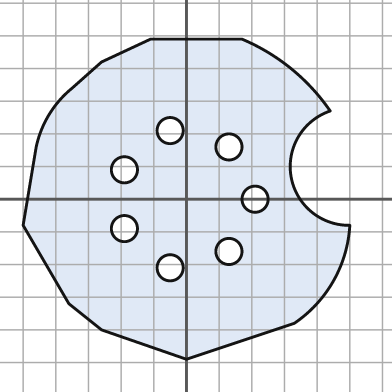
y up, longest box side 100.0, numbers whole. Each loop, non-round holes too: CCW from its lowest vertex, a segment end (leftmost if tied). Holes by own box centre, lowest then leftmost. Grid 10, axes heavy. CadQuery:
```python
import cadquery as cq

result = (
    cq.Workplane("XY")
    .moveTo(0.0, -49.0)
    .lineTo(33.0, -38.0)
    .threePointArc((45.0, -25.0), (50.0, -8.0))
    .threePointArc((32.0, 7.0), (44.0, 27.0))
    .threePointArc((32.0, 40.0), (17.0, 49.0))
    .lineTo(-11.0, 49.0)
    .lineTo(-26.0, 42.0)
    .lineTo(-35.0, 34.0)
    .threePointArc((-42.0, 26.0), (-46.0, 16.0))
    .lineTo(-50.0, -8.0)
    .lineTo(-36.0, -32.0)
    .lineTo(-26.0, -40.0)
    .close()
    .moveTo(-5.0, -21.0)
    .circle(4.0)
    .moveTo(13.0, -16.0)
    .circle(4.0)
    .moveTo(-19.0, -9.0)
    .circle(4.0)
    .moveTo(21.0, 0.0)
    .circle(4.0)
    .moveTo(-19.0, 9.0)
    .circle(4.0)
    .moveTo(13.0, 16.0)
    .circle(4.0)
    .moveTo(-5.0, 21.0)
    .circle(4.0)
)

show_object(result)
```